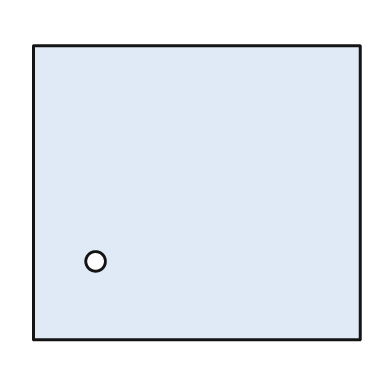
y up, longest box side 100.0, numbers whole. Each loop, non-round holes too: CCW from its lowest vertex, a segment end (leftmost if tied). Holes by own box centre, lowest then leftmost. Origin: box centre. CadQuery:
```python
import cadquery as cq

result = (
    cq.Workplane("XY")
    .moveTo(-50.0, -45.0)
    .lineTo(50.0, -45.0)
    .lineTo(50.0, 45.0)
    .lineTo(-50.0, 45.0)
    .close()
    .moveTo(-31.0, -21.0)
    .circle(3.0)
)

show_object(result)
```